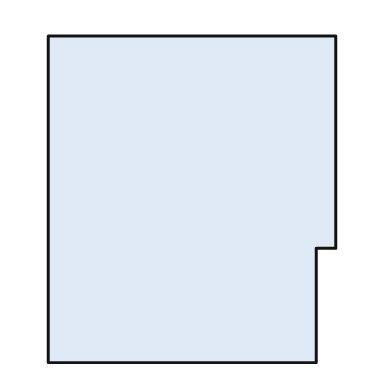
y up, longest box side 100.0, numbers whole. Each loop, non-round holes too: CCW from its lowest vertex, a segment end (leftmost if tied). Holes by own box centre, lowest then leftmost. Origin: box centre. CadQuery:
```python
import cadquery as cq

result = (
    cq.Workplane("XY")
    .moveTo(-44.0, -50.0)
    .lineTo(38.0, -50.0)
    .lineTo(38.0, -15.0)
    .lineTo(44.0, -15.0)
    .lineTo(44.0, 50.0)
    .lineTo(-44.0, 50.0)
    .close()
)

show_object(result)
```